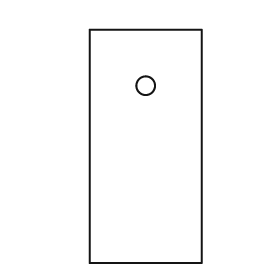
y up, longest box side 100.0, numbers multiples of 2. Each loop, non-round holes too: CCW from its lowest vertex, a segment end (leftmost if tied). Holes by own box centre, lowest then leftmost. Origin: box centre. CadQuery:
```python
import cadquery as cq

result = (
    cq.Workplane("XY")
    .moveTo(-24.0, -50.0)
    .lineTo(24.0, -50.0)
    .lineTo(24.0, 50.0)
    .lineTo(-24.0, 50.0)
    .close()
    .moveTo(0.0, 26.0)
    .circle(4.0)
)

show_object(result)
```